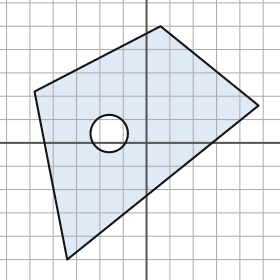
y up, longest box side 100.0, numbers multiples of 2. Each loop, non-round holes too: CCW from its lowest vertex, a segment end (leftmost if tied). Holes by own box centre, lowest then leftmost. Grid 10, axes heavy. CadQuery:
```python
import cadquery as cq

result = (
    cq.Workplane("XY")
    .moveTo(-34.0, -50.0)
    .lineTo(48.0, 16.0)
    .lineTo(6.0, 50.0)
    .lineTo(-48.0, 22.0)
    .close()
    .moveTo(-16.0, 4.0)
    .circle(8.0)
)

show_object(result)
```